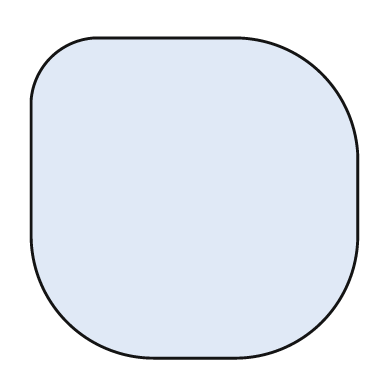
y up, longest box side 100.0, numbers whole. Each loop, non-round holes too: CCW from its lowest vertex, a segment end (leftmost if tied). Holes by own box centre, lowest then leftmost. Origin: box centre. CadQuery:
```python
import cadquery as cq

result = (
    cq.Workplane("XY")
    .moveTo(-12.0, -49.0)
    .lineTo(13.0, -49.0)
    .threePointArc((39.0, -38.0), (50.0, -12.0))
    .lineTo(50.0, 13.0)
    .threePointArc((39.0, 38.0), (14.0, 49.0))
    .lineTo(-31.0, 49.0)
    .threePointArc((-44.0, 43.0), (-50.0, 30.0))
    .lineTo(-50.0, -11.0)
    .threePointArc((-39.0, -38.0), (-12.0, -49.0))
    .close()
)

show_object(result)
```